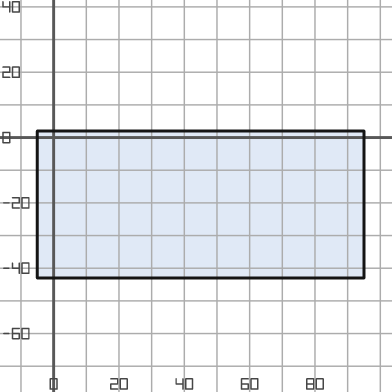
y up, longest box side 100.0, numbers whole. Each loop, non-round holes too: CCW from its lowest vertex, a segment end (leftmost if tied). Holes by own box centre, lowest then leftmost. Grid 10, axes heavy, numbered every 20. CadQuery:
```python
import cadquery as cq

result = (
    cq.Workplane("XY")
    .moveTo(-5.0, -43.0)
    .lineTo(95.0, -43.0)
    .lineTo(95.0, 2.0)
    .lineTo(-5.0, 2.0)
    .close()
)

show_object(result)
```